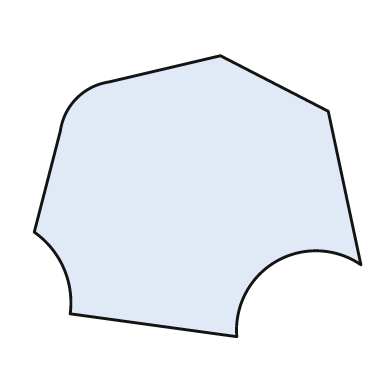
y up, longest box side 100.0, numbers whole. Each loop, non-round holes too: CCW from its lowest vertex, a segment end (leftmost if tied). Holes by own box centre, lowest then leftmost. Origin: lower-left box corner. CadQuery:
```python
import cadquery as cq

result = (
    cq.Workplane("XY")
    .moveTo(62.0, 0.0)
    .threePointArc((74.0, 23.0), (100.0, 22.0))
    .lineTo(90.0, 69.0)
    .lineTo(57.0, 86.0)
    .lineTo(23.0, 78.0)
    .threePointArc((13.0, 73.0), (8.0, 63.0))
    .lineTo(0.0, 32.0)
    .threePointArc((9.0, 21.0), (11.0, 7.0))
    .close()
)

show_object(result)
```